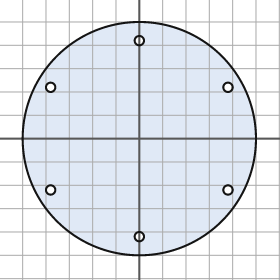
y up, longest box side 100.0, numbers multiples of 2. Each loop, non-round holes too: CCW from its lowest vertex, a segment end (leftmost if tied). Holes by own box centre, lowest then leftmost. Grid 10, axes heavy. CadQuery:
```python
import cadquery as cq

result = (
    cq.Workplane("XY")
    .moveTo(0.0, 0.0)
    .circle(50.0)
    .moveTo(0.0, -42.0)
    .circle(2.0)
    .moveTo(-38.0, -22.0)
    .circle(2.0)
    .moveTo(38.0, -22.0)
    .circle(2.0)
    .moveTo(-38.0, 22.0)
    .circle(2.0)
    .moveTo(38.0, 22.0)
    .circle(2.0)
    .moveTo(0.0, 42.0)
    .circle(2.0)
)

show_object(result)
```